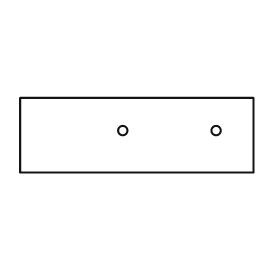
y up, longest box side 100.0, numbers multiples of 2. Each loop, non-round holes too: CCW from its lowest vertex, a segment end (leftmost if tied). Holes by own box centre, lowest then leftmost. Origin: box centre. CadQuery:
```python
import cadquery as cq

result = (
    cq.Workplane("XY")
    .moveTo(-50.0, -16.0)
    .lineTo(50.0, -16.0)
    .lineTo(50.0, 16.0)
    .lineTo(-50.0, 16.0)
    .close()
    .moveTo(-6.0, 2.0)
    .circle(2.0)
    .moveTo(34.0, 2.0)
    .circle(2.0)
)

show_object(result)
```